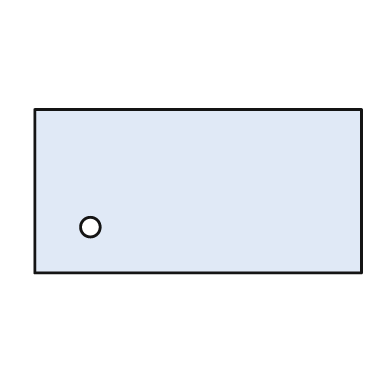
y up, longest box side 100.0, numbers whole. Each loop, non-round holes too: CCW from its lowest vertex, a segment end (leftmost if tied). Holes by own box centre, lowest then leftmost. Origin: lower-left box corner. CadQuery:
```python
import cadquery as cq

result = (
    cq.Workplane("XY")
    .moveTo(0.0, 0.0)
    .lineTo(100.0, 0.0)
    .lineTo(100.0, 50.0)
    .lineTo(0.0, 50.0)
    .close()
    .moveTo(17.0, 14.0)
    .circle(3.0)
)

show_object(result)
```